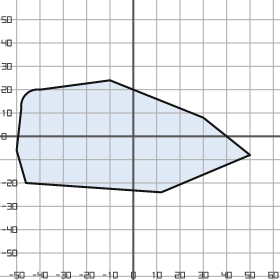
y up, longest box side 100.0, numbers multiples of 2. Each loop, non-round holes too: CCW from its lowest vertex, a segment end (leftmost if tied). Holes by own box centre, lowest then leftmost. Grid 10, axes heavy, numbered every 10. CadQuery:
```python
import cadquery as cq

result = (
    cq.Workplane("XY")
    .moveTo(12.0, -24.0)
    .lineTo(50.0, -8.0)
    .lineTo(30.0, 8.0)
    .lineTo(-10.0, 24.0)
    .lineTo(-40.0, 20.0)
    .threePointArc((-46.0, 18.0), (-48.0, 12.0))
    .lineTo(-50.0, -6.0)
    .lineTo(-46.0, -20.0)
    .close()
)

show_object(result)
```